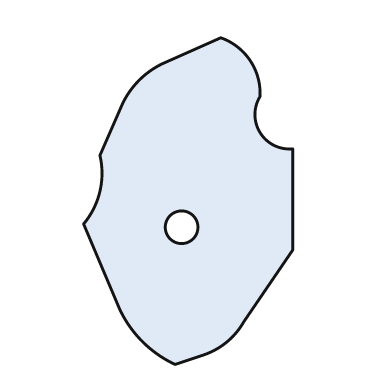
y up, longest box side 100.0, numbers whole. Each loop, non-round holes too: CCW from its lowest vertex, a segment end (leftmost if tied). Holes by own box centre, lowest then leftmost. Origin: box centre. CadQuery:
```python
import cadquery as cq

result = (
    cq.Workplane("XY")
    .moveTo(-4.0, -50.0)
    .lineTo(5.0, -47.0)
    .threePointArc((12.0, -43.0), (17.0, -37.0))
    .lineTo(32.0, -15.0)
    .lineTo(32.0, 16.0)
    .threePointArc((22.0, 21.0), (22.0, 32.0))
    .threePointArc((19.0, 43.0), (10.0, 50.0))
    .lineTo(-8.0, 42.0)
    .threePointArc((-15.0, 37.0), (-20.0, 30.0))
    .lineTo(-27.0, 14.0)
    .threePointArc((-27.0, 3.0), (-32.0, -7.0))
    .lineTo(-21.0, -33.0)
    .threePointArc((-14.0, -43.0), (-4.0, -50.0))
    .close()
    .moveTo(-2.0, -8.0)
    .circle(5.0)
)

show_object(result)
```